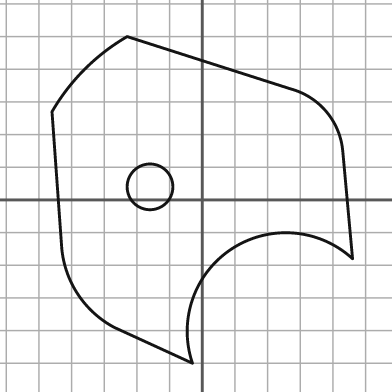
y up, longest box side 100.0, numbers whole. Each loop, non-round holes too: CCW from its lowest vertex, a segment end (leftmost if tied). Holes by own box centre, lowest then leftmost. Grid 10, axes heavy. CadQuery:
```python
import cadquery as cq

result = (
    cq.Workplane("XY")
    .moveTo(-3.0, -50.0)
    .threePointArc((9.0, -15.0), (46.0, -18.0))
    .lineTo(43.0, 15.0)
    .threePointArc((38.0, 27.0), (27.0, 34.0))
    .lineTo(-23.0, 50.0)
    .threePointArc((-36.0, 40.0), (-46.0, 27.0))
    .lineTo(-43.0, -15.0)
    .threePointArc((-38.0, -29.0), (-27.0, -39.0))
    .close()
    .moveTo(-16.0, 4.0)
    .circle(7.0)
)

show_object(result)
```